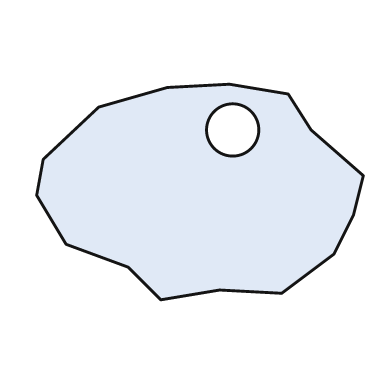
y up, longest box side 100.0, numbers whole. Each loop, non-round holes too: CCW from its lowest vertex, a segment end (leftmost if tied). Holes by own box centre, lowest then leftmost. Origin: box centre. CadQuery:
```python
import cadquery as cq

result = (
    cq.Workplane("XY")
    .moveTo(-12.0, -33.0)
    .lineTo(6.0, -30.0)
    .lineTo(25.0, -31.0)
    .lineTo(41.0, -19.0)
    .lineTo(47.0, -7.0)
    .lineTo(50.0, 5.0)
    .lineTo(34.0, 19.0)
    .lineTo(27.0, 30.0)
    .lineTo(9.0, 33.0)
    .lineTo(-10.0, 32.0)
    .lineTo(-31.0, 26.0)
    .lineTo(-48.0, 10.0)
    .lineTo(-50.0, -1.0)
    .lineTo(-41.0, -16.0)
    .lineTo(-22.0, -23.0)
    .close()
    .moveTo(10.0, 19.0)
    .circle(8.0)
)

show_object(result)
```